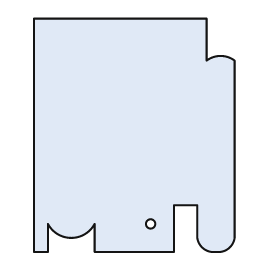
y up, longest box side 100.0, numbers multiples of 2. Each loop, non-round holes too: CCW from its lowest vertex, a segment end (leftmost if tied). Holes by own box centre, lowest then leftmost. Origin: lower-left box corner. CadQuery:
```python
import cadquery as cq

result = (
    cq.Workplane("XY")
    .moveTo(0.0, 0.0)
    .lineTo(6.0, 0.0)
    .lineTo(6.0, 12.0)
    .threePointArc((16.0, 6.0), (26.0, 12.0))
    .lineTo(26.0, 0.0)
    .lineTo(60.0, 0.0)
    .lineTo(60.0, 20.0)
    .lineTo(70.0, 20.0)
    .lineTo(70.0, 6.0)
    .threePointArc((72.0, 2.0), (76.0, 0.0))
    .lineTo(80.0, 0.0)
    .threePointArc((84.0, 2.0), (86.0, 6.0))
    .lineTo(86.0, 82.0)
    .threePointArc((80.0, 84.0), (74.0, 82.0))
    .lineTo(74.0, 100.0)
    .lineTo(0.0, 100.0)
    .close()
    .moveTo(50.0, 12.0)
    .circle(2.0)
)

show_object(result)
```